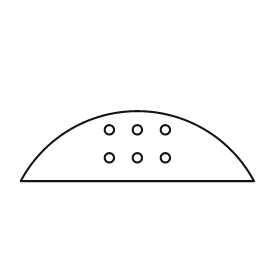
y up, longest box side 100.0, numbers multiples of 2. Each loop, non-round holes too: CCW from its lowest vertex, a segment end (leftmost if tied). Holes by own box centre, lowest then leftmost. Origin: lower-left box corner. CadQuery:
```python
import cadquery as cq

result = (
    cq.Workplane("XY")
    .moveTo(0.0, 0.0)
    .lineTo(100.0, 0.0)
    .threePointArc((50.0, 30.0), (0.0, 0.0))
    .close()
    .moveTo(38.0, 10.0)
    .circle(2.0)
    .moveTo(50.0, 10.0)
    .circle(2.0)
    .moveTo(62.0, 10.0)
    .circle(2.0)
    .moveTo(38.0, 22.0)
    .circle(2.0)
    .moveTo(50.0, 22.0)
    .circle(2.0)
    .moveTo(62.0, 22.0)
    .circle(2.0)
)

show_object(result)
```